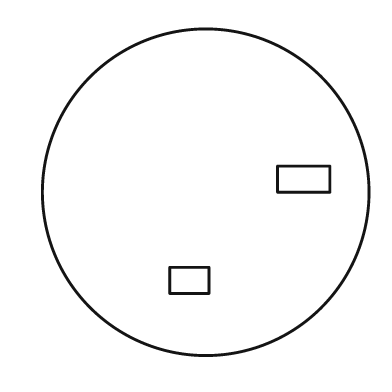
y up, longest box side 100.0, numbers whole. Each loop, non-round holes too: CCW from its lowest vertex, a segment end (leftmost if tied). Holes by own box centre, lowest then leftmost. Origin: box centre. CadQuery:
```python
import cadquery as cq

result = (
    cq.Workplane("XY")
    .moveTo(0.0, 0.0)
    .circle(50.0)
    .moveTo(-11.0, -31.0)
    .lineTo(1.0, -31.0)
    .lineTo(1.0, -23.0)
    .lineTo(-11.0, -23.0)
    .close()
    .moveTo(22.0, 0.0)
    .lineTo(38.0, 0.0)
    .lineTo(38.0, 8.0)
    .lineTo(22.0, 8.0)
    .close()
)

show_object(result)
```